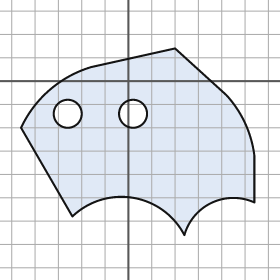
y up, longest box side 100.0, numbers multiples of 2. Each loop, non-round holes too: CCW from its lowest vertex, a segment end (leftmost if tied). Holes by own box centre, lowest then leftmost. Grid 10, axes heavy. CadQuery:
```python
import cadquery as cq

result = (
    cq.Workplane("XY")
    .moveTo(24.0, -66.0)
    .threePointArc((36.0, -52.0), (54.0, -52.0))
    .lineTo(54.0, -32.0)
    .threePointArc((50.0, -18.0), (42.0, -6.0))
    .lineTo(20.0, 14.0)
    .lineTo(-16.0, 6.0)
    .threePointArc((-34.0, -4.0), (-46.0, -20.0))
    .lineTo(-24.0, -58.0)
    .threePointArc((2.0, -50.0), (24.0, -66.0))
    .close()
    .moveTo(-26.0, -14.0)
    .circle(6.0)
    .moveTo(2.0, -14.0)
    .circle(6.0)
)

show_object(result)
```